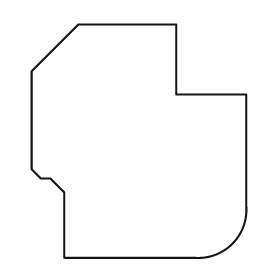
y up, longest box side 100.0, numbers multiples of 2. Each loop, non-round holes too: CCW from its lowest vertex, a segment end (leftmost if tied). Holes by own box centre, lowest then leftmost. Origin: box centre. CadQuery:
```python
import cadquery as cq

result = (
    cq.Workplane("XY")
    .moveTo(-32.0, -50.0)
    .lineTo(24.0, -50.0)
    .threePointArc((40.0, -44.0), (46.0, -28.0))
    .lineTo(46.0, 20.0)
    .lineTo(16.0, 20.0)
    .lineTo(16.0, 50.0)
    .lineTo(-26.0, 50.0)
    .lineTo(-46.0, 30.0)
    .lineTo(-46.0, -12.0)
    .lineTo(-42.0, -16.0)
    .lineTo(-38.0, -16.0)
    .lineTo(-32.0, -22.0)
    .close()
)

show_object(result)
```